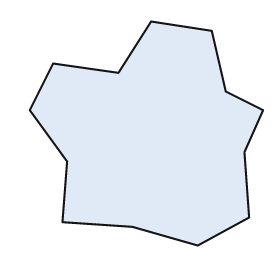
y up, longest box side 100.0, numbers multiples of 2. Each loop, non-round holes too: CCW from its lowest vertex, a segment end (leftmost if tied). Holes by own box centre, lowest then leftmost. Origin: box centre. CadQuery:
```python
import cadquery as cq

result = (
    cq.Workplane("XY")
    .moveTo(22.0, -48.0)
    .lineTo(44.0, -36.0)
    .lineTo(42.0, -8.0)
    .lineTo(50.0, 10.0)
    .lineTo(34.0, 18.0)
    .lineTo(28.0, 44.0)
    .lineTo(2.0, 48.0)
    .lineTo(-12.0, 26.0)
    .lineTo(-40.0, 30.0)
    .lineTo(-50.0, 10.0)
    .lineTo(-34.0, -12.0)
    .lineTo(-36.0, -38.0)
    .lineTo(-6.0, -40.0)
    .close()
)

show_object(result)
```